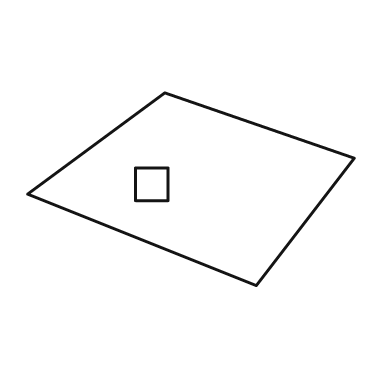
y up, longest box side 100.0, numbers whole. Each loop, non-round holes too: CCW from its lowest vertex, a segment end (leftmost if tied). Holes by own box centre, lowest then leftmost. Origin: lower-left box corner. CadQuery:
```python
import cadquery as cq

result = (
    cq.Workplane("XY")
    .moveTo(70.0, 0.0)
    .lineTo(100.0, 39.0)
    .lineTo(42.0, 59.0)
    .lineTo(0.0, 28.0)
    .close()
    .moveTo(33.0, 26.0)
    .lineTo(43.0, 26.0)
    .lineTo(43.0, 36.0)
    .lineTo(33.0, 36.0)
    .close()
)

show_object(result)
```